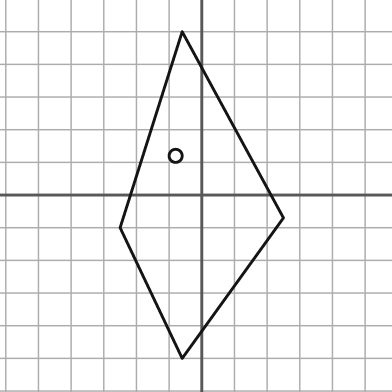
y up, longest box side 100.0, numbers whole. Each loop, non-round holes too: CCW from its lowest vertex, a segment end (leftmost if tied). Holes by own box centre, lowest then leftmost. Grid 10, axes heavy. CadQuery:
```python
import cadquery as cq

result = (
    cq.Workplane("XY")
    .moveTo(-6.0, -50.0)
    .lineTo(25.0, -7.0)
    .lineTo(-6.0, 50.0)
    .lineTo(-25.0, -10.0)
    .close()
    .moveTo(-8.0, 12.0)
    .circle(2.0)
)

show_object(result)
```